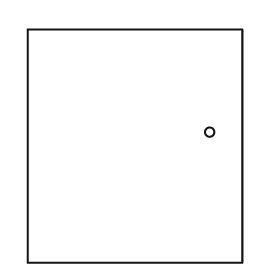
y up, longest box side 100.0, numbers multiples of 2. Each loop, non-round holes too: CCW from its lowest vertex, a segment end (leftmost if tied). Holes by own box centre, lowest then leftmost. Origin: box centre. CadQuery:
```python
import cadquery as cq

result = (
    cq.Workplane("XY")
    .moveTo(-46.0, -50.0)
    .lineTo(46.0, -50.0)
    .lineTo(46.0, 50.0)
    .lineTo(-46.0, 50.0)
    .close()
    .moveTo(32.0, 6.0)
    .circle(2.0)
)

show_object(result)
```